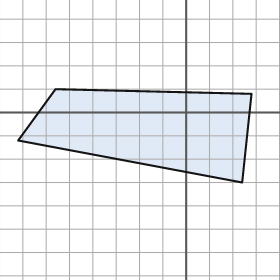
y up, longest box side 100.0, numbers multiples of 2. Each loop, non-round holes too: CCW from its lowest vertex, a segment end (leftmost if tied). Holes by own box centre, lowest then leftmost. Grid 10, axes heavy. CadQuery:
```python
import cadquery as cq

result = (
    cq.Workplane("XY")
    .moveTo(24.0, -30.0)
    .lineTo(28.0, 8.0)
    .lineTo(-56.0, 10.0)
    .lineTo(-72.0, -12.0)
    .close()
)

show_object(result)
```